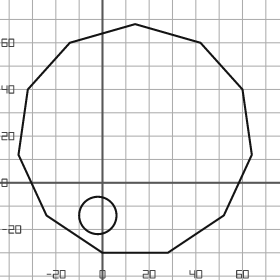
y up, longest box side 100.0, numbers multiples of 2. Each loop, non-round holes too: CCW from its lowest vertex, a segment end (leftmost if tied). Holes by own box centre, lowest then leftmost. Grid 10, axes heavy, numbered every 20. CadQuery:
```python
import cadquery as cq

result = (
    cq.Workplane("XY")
    .moveTo(0.0, -30.0)
    .lineTo(28.0, -30.0)
    .lineTo(52.0, -14.0)
    .lineTo(64.0, 12.0)
    .lineTo(60.0, 40.0)
    .lineTo(42.0, 60.0)
    .lineTo(14.0, 68.0)
    .lineTo(-14.0, 60.0)
    .lineTo(-32.0, 40.0)
    .lineTo(-36.0, 12.0)
    .lineTo(-24.0, -14.0)
    .close()
    .moveTo(-2.0, -14.0)
    .circle(8.0)
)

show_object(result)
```